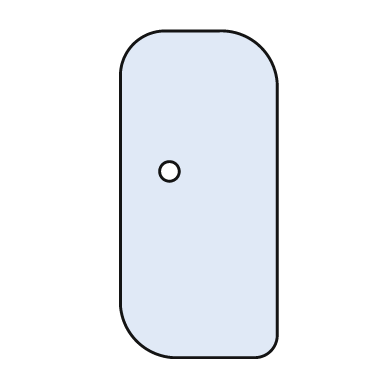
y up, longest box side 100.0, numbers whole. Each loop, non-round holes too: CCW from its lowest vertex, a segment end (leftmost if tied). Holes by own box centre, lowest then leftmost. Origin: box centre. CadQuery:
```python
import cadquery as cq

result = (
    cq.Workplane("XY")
    .moveTo(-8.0, -50.0)
    .lineTo(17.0, -50.0)
    .threePointArc((22.0, -48.0), (24.0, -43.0))
    .lineTo(24.0, 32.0)
    .threePointArc((19.0, 45.0), (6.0, 50.0))
    .lineTo(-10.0, 50.0)
    .threePointArc((-20.0, 46.0), (-24.0, 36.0))
    .lineTo(-24.0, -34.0)
    .threePointArc((-19.0, -45.0), (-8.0, -50.0))
    .close()
    .moveTo(-9.0, 7.0)
    .circle(3.0)
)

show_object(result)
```